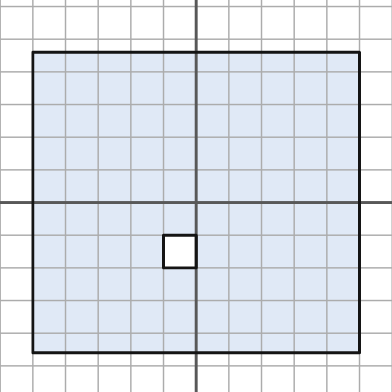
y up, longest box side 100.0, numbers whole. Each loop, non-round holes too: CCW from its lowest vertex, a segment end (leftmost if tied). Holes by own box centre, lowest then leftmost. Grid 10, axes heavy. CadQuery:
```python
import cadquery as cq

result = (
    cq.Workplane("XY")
    .moveTo(-50.0, -46.0)
    .lineTo(50.0, -46.0)
    .lineTo(50.0, 46.0)
    .lineTo(-50.0, 46.0)
    .close()
    .moveTo(-10.0, -20.0)
    .lineTo(0.0, -20.0)
    .lineTo(0.0, -10.0)
    .lineTo(-10.0, -10.0)
    .close()
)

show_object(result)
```